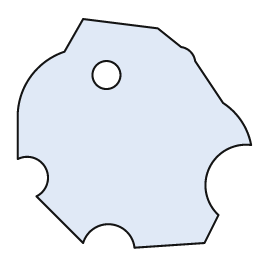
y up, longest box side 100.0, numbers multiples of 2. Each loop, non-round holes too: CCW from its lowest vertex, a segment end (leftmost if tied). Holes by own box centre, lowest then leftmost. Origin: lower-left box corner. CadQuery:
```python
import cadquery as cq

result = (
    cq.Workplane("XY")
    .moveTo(50.0, 0.0)
    .lineTo(80.0, 2.0)
    .lineTo(86.0, 14.0)
    .threePointArc((82.0, 34.0), (100.0, 44.0))
    .threePointArc((96.0, 54.0), (88.0, 62.0))
    .lineTo(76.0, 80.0)
    .threePointArc((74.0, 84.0), (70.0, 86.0))
    .lineTo(60.0, 94.0)
    .lineTo(28.0, 98.0)
    .lineTo(20.0, 84.0)
    .threePointArc((6.0, 74.0), (0.0, 58.0))
    .lineTo(0.0, 38.0)
    .threePointArc((12.0, 34.0), (8.0, 22.0))
    .lineTo(28.0, 2.0)
    .threePointArc((40.0, 10.0), (50.0, 0.0))
    .close()
    .moveTo(38.0, 74.0)
    .circle(6.0)
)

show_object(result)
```